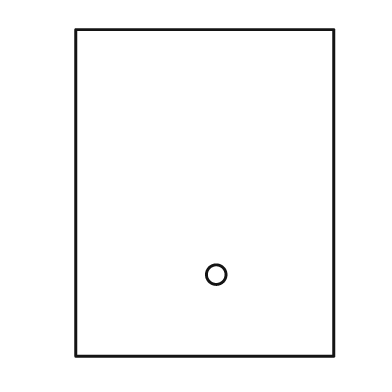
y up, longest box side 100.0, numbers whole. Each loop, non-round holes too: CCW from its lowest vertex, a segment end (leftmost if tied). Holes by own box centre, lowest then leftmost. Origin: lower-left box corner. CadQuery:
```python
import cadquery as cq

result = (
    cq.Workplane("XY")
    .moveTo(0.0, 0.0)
    .lineTo(79.0, 0.0)
    .lineTo(79.0, 100.0)
    .lineTo(0.0, 100.0)
    .close()
    .moveTo(43.0, 25.0)
    .circle(3.0)
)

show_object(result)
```